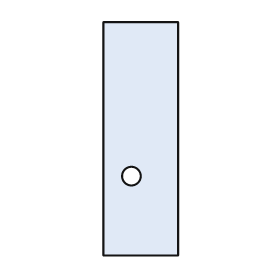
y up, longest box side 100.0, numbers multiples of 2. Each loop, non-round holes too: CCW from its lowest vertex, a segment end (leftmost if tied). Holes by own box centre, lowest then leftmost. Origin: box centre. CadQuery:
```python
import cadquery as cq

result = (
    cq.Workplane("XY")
    .moveTo(-16.0, -50.0)
    .lineTo(16.0, -50.0)
    .lineTo(16.0, 50.0)
    .lineTo(-16.0, 50.0)
    .close()
    .moveTo(-4.0, -16.0)
    .circle(4.0)
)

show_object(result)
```